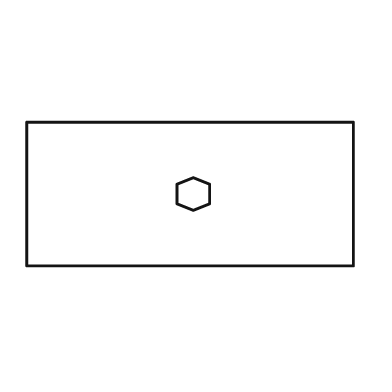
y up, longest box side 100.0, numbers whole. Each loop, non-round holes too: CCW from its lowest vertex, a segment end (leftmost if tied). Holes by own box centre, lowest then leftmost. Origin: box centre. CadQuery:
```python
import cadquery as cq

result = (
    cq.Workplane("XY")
    .moveTo(-50.0, -22.0)
    .lineTo(50.0, -22.0)
    .lineTo(50.0, 22.0)
    .lineTo(-50.0, 22.0)
    .close()
    .moveTo(1.0, -5.0)
    .lineTo(6.0, -3.0)
    .lineTo(6.0, 3.0)
    .lineTo(1.0, 5.0)
    .lineTo(-4.0, 3.0)
    .lineTo(-4.0, -3.0)
    .close()
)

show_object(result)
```